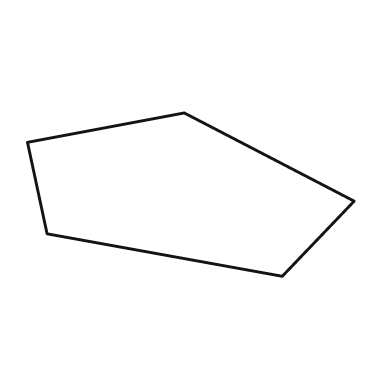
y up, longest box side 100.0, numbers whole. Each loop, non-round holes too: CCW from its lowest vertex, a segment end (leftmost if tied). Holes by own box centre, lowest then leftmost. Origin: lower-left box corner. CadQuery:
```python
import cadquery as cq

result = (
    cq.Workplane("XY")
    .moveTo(78.0, 0.0)
    .lineTo(100.0, 23.0)
    .lineTo(48.0, 50.0)
    .lineTo(0.0, 41.0)
    .lineTo(6.0, 13.0)
    .close()
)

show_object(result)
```